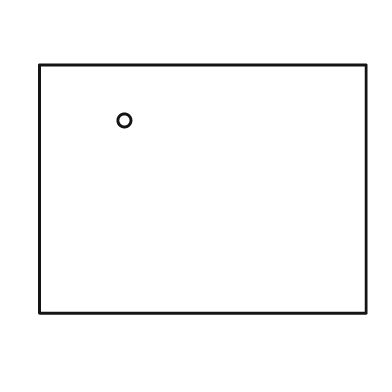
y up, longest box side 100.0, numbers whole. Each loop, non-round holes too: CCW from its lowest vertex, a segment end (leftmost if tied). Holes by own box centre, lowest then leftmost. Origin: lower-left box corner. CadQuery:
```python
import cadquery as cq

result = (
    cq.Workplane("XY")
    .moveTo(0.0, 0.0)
    .lineTo(100.0, 0.0)
    .lineTo(100.0, 76.0)
    .lineTo(0.0, 76.0)
    .close()
    .moveTo(26.0, 59.0)
    .circle(2.0)
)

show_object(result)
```